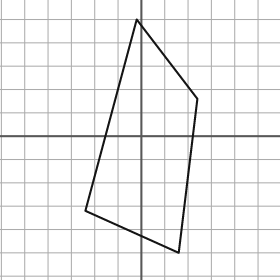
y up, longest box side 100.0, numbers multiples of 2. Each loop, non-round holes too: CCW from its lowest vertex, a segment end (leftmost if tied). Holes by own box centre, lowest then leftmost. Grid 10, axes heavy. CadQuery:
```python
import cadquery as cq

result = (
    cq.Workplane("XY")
    .moveTo(16.0, -50.0)
    .lineTo(24.0, 16.0)
    .lineTo(-2.0, 50.0)
    .lineTo(-24.0, -32.0)
    .close()
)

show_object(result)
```